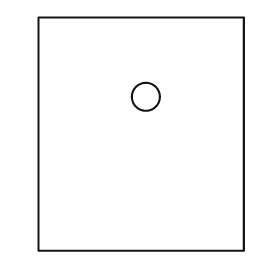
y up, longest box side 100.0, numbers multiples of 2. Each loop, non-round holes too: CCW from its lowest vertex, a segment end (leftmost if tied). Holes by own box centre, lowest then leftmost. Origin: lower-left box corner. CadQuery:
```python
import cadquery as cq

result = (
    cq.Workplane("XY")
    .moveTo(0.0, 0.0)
    .lineTo(88.0, 0.0)
    .lineTo(88.0, 100.0)
    .lineTo(0.0, 100.0)
    .close()
    .moveTo(46.0, 66.0)
    .circle(6.0)
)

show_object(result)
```